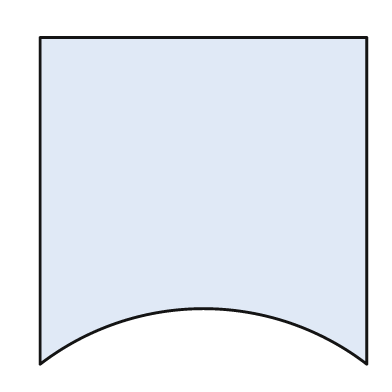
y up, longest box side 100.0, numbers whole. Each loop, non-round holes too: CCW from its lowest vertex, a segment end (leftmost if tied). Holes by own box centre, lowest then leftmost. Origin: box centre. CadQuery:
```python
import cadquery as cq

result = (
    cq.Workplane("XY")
    .moveTo(-50.0, -50.0)
    .threePointArc((0.0, -33.0), (50.0, -50.0))
    .lineTo(50.0, 50.0)
    .lineTo(-50.0, 50.0)
    .close()
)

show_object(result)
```